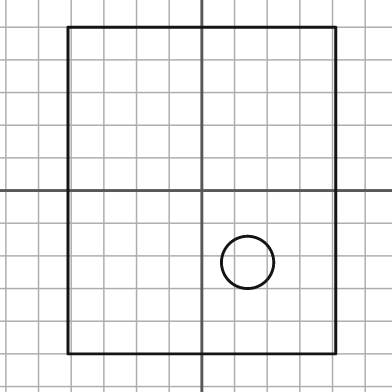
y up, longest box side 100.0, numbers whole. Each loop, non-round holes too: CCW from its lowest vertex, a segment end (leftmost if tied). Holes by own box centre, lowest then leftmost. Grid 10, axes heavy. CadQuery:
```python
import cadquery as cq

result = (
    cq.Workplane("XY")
    .moveTo(-41.0, -50.0)
    .lineTo(41.0, -50.0)
    .lineTo(41.0, 50.0)
    .lineTo(-41.0, 50.0)
    .close()
    .moveTo(14.0, -22.0)
    .circle(8.0)
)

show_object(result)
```